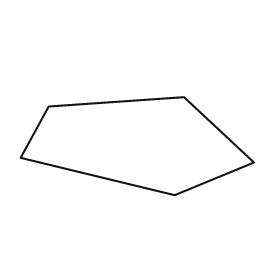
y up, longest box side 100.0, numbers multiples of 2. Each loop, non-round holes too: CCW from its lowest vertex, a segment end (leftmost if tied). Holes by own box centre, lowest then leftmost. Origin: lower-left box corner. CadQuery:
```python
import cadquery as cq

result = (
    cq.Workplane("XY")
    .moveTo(66.0, 0.0)
    .lineTo(100.0, 14.0)
    .lineTo(70.0, 42.0)
    .lineTo(12.0, 38.0)
    .lineTo(0.0, 16.0)
    .close()
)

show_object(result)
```